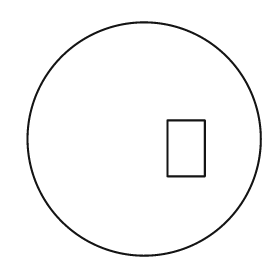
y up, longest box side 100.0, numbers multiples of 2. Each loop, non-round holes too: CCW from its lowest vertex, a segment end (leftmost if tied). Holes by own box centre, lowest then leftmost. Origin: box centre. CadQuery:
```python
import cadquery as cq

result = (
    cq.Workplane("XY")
    .moveTo(0.0, 0.0)
    .circle(50.0)
    .moveTo(10.0, -16.0)
    .lineTo(26.0, -16.0)
    .lineTo(26.0, 8.0)
    .lineTo(10.0, 8.0)
    .close()
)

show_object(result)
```